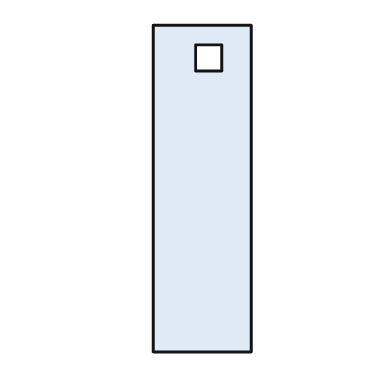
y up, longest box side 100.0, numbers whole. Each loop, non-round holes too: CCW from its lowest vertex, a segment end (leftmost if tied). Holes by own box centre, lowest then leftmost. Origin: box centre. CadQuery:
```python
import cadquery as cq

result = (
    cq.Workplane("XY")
    .moveTo(-15.0, -50.0)
    .lineTo(15.0, -50.0)
    .lineTo(15.0, 50.0)
    .lineTo(-15.0, 50.0)
    .close()
    .moveTo(-2.0, 36.0)
    .lineTo(6.0, 36.0)
    .lineTo(6.0, 44.0)
    .lineTo(-2.0, 44.0)
    .close()
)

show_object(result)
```